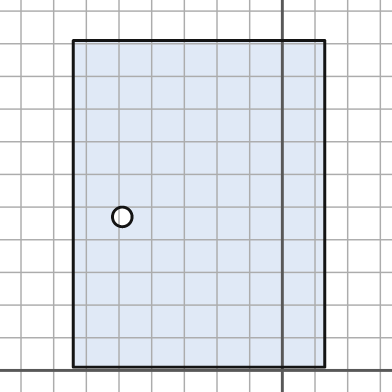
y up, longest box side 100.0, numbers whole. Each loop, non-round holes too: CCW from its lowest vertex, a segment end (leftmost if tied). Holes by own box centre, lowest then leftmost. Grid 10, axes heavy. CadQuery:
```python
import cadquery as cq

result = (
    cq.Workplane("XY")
    .moveTo(-64.0, 1.0)
    .lineTo(13.0, 1.0)
    .lineTo(13.0, 101.0)
    .lineTo(-64.0, 101.0)
    .close()
    .moveTo(-49.0, 47.0)
    .circle(3.0)
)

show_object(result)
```